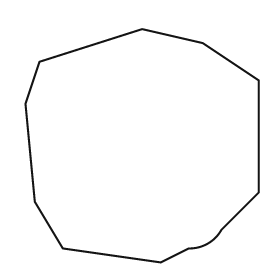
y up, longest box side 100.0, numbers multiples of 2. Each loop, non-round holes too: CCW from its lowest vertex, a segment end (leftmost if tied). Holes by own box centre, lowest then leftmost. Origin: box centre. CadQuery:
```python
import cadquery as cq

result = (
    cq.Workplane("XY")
    .moveTo(8.0, -50.0)
    .lineTo(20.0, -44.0)
    .threePointArc((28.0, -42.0), (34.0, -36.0))
    .lineTo(50.0, -20.0)
    .lineTo(50.0, 28.0)
    .lineTo(26.0, 44.0)
    .lineTo(0.0, 50.0)
    .lineTo(-44.0, 36.0)
    .lineTo(-50.0, 18.0)
    .lineTo(-46.0, -24.0)
    .lineTo(-34.0, -44.0)
    .close()
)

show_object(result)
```